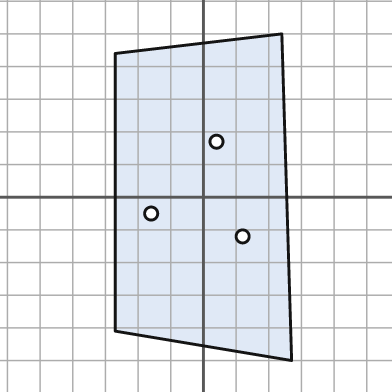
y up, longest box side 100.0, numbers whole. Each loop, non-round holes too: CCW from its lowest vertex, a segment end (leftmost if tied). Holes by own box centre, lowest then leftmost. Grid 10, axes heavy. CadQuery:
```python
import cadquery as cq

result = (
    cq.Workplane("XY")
    .moveTo(27.0, -50.0)
    .lineTo(24.0, 50.0)
    .lineTo(-27.0, 44.0)
    .lineTo(-27.0, -41.0)
    .close()
    .moveTo(12.0, -12.0)
    .circle(2.0)
    .moveTo(-16.0, -5.0)
    .circle(2.0)
    .moveTo(4.0, 17.0)
    .circle(2.0)
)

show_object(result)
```